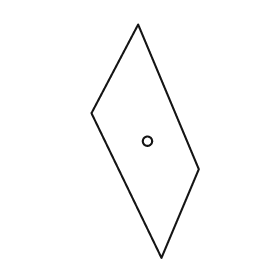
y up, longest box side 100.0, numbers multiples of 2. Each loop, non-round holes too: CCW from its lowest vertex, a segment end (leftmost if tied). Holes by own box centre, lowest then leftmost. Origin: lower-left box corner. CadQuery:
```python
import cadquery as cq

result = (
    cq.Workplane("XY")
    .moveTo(30.0, 0.0)
    .lineTo(46.0, 38.0)
    .lineTo(20.0, 100.0)
    .lineTo(0.0, 62.0)
    .close()
    .moveTo(24.0, 50.0)
    .circle(2.0)
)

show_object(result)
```